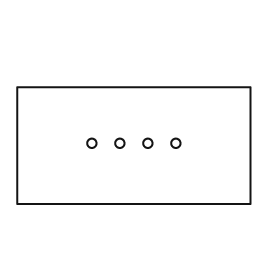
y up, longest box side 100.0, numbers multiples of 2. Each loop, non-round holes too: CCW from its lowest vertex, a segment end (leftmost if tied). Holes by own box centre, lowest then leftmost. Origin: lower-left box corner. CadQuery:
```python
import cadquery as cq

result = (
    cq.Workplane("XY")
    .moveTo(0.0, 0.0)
    .lineTo(100.0, 0.0)
    .lineTo(100.0, 50.0)
    .lineTo(0.0, 50.0)
    .close()
    .moveTo(32.0, 26.0)
    .circle(2.0)
    .moveTo(44.0, 26.0)
    .circle(2.0)
    .moveTo(56.0, 26.0)
    .circle(2.0)
    .moveTo(68.0, 26.0)
    .circle(2.0)
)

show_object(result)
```